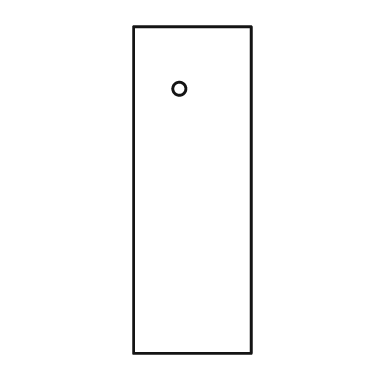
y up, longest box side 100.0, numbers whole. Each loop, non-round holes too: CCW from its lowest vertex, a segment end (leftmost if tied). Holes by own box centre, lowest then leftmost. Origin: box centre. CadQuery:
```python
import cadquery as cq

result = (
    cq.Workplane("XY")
    .moveTo(-18.0, -50.0)
    .lineTo(18.0, -50.0)
    .lineTo(18.0, 50.0)
    .lineTo(-18.0, 50.0)
    .close()
    .moveTo(-4.0, 31.0)
    .circle(2.0)
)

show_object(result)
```